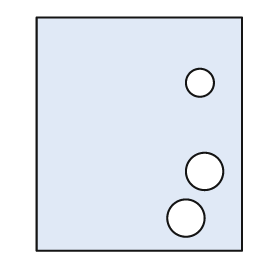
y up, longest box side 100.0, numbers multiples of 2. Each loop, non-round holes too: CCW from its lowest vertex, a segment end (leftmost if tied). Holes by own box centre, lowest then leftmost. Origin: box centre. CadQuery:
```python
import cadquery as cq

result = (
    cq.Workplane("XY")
    .moveTo(-44.0, -50.0)
    .lineTo(44.0, -50.0)
    .lineTo(44.0, 50.0)
    .lineTo(-44.0, 50.0)
    .close()
    .moveTo(20.0, -36.0)
    .circle(8.0)
    .moveTo(28.0, -16.0)
    .circle(8.0)
    .moveTo(26.0, 22.0)
    .circle(6.0)
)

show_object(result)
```